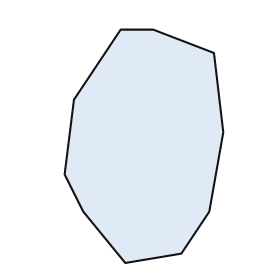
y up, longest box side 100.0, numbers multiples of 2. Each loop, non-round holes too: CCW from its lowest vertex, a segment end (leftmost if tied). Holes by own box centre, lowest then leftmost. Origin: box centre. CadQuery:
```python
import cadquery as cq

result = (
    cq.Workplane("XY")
    .moveTo(-8.0, -50.0)
    .lineTo(16.0, -46.0)
    .lineTo(28.0, -28.0)
    .lineTo(34.0, 6.0)
    .lineTo(30.0, 40.0)
    .lineTo(4.0, 50.0)
    .lineTo(-10.0, 50.0)
    .lineTo(-30.0, 20.0)
    .lineTo(-34.0, -12.0)
    .lineTo(-26.0, -28.0)
    .close()
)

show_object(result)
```